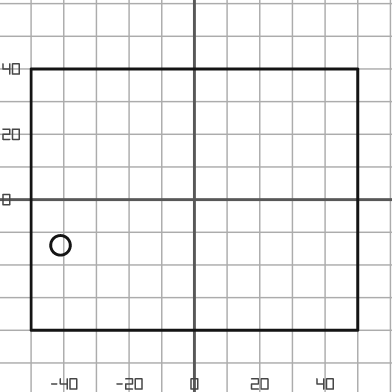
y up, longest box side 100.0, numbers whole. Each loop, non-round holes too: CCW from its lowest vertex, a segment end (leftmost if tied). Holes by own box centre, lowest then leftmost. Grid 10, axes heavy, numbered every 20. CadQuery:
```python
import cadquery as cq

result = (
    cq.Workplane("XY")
    .moveTo(-50.0, -40.0)
    .lineTo(50.0, -40.0)
    .lineTo(50.0, 40.0)
    .lineTo(-50.0, 40.0)
    .close()
    .moveTo(-41.0, -14.0)
    .circle(3.0)
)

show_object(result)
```